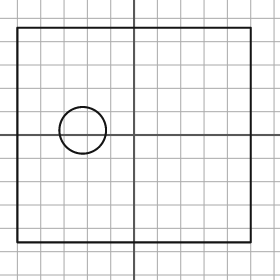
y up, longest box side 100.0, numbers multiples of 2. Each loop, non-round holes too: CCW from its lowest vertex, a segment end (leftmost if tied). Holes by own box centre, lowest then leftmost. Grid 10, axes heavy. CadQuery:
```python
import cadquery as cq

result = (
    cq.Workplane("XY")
    .moveTo(-50.0, -46.0)
    .lineTo(50.0, -46.0)
    .lineTo(50.0, 46.0)
    .lineTo(-50.0, 46.0)
    .close()
    .moveTo(-22.0, 2.0)
    .circle(10.0)
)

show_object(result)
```